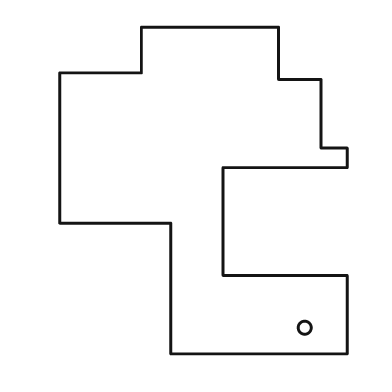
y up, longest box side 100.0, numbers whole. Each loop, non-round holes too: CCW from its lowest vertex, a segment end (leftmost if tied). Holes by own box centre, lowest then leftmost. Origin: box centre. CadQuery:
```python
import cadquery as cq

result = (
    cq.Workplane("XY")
    .moveTo(-10.0, -50.0)
    .lineTo(44.0, -50.0)
    .lineTo(44.0, -26.0)
    .lineTo(6.0, -26.0)
    .lineTo(6.0, 7.0)
    .lineTo(44.0, 7.0)
    .lineTo(44.0, 13.0)
    .lineTo(36.0, 13.0)
    .lineTo(36.0, 34.0)
    .lineTo(23.0, 34.0)
    .lineTo(23.0, 50.0)
    .lineTo(-19.0, 50.0)
    .lineTo(-19.0, 36.0)
    .lineTo(-44.0, 36.0)
    .lineTo(-44.0, -10.0)
    .lineTo(-10.0, -10.0)
    .close()
    .moveTo(31.0, -42.0)
    .circle(2.0)
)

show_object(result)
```